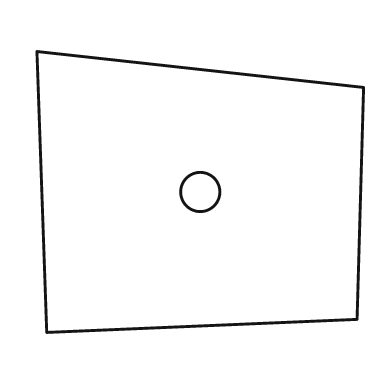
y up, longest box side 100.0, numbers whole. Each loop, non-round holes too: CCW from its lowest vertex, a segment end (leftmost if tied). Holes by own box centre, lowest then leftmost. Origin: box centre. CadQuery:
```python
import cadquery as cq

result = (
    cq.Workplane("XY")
    .moveTo(-47.0, -43.0)
    .lineTo(48.0, -39.0)
    .lineTo(50.0, 32.0)
    .lineTo(-50.0, 43.0)
    .close()
    .moveTo(0.0, 0.0)
    .circle(6.0)
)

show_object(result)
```